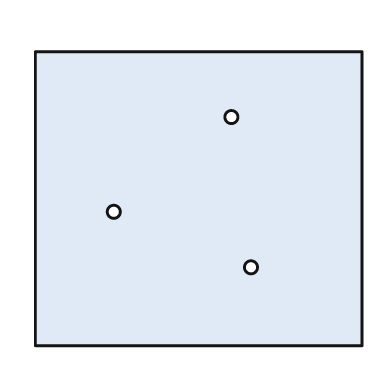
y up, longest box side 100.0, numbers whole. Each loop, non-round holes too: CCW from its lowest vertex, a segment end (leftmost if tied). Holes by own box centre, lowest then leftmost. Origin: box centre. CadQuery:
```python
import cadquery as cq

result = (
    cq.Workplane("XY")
    .moveTo(-50.0, -45.0)
    .lineTo(50.0, -45.0)
    .lineTo(50.0, 45.0)
    .lineTo(-50.0, 45.0)
    .close()
    .moveTo(16.0, -21.0)
    .circle(2.0)
    .moveTo(-26.0, -4.0)
    .circle(2.0)
    .moveTo(10.0, 25.0)
    .circle(2.0)
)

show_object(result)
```